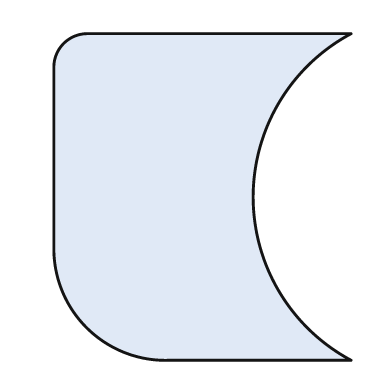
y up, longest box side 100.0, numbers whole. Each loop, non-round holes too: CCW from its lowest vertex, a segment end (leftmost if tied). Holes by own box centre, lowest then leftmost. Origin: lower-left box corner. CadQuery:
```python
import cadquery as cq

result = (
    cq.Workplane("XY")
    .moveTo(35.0, 0.0)
    .lineTo(91.0, 0.0)
    .threePointArc((61.0, 50.0), (91.0, 100.0))
    .lineTo(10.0, 100.0)
    .threePointArc((3.0, 97.0), (0.0, 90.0))
    .lineTo(0.0, 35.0)
    .threePointArc((10.0, 10.0), (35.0, 0.0))
    .close()
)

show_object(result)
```